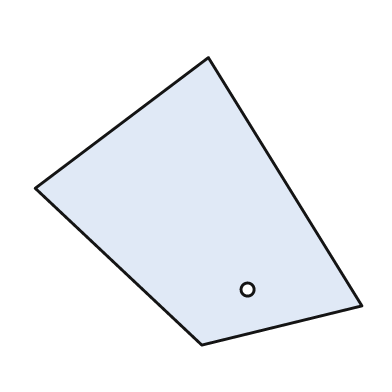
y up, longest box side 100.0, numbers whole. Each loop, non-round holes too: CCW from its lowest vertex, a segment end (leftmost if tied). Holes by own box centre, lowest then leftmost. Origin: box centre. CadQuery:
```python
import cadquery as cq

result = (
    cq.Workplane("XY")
    .moveTo(1.0, -44.0)
    .lineTo(50.0, -32.0)
    .lineTo(3.0, 44.0)
    .lineTo(-50.0, 4.0)
    .close()
    .moveTo(15.0, -27.0)
    .circle(2.0)
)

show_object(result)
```